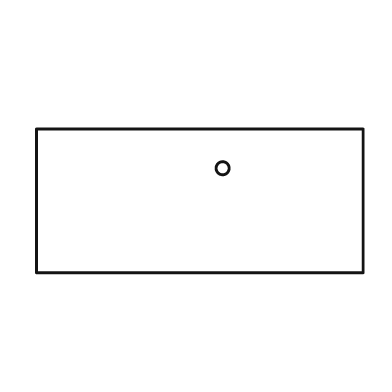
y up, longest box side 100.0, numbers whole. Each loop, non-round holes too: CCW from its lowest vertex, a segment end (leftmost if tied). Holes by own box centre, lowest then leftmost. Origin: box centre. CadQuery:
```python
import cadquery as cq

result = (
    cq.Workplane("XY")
    .moveTo(-50.0, -22.0)
    .lineTo(50.0, -22.0)
    .lineTo(50.0, 22.0)
    .lineTo(-50.0, 22.0)
    .close()
    .moveTo(7.0, 10.0)
    .circle(2.0)
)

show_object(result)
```